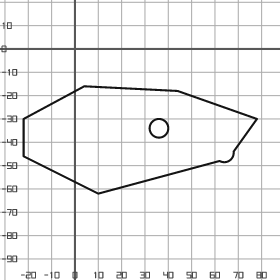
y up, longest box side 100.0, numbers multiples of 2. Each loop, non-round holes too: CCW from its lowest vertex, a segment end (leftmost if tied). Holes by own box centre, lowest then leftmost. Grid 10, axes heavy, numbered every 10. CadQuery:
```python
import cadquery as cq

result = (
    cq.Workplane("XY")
    .moveTo(10.0, -62.0)
    .lineTo(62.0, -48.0)
    .threePointArc((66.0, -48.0), (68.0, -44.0))
    .lineTo(78.0, -30.0)
    .lineTo(44.0, -18.0)
    .lineTo(4.0, -16.0)
    .lineTo(-22.0, -30.0)
    .lineTo(-22.0, -46.0)
    .close()
    .moveTo(36.0, -34.0)
    .circle(4.0)
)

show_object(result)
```